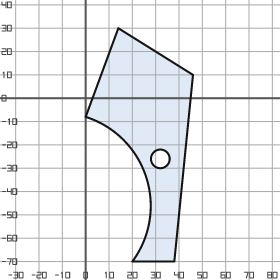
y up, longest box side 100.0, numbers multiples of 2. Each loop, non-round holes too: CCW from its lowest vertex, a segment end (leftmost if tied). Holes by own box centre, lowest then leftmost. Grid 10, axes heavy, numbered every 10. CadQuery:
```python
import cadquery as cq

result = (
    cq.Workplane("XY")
    .moveTo(20.0, -70.0)
    .lineTo(38.0, -70.0)
    .lineTo(46.0, 10.0)
    .lineTo(14.0, 30.0)
    .lineTo(0.0, -8.0)
    .threePointArc((26.0, -34.0), (20.0, -70.0))
    .close()
    .moveTo(32.0, -26.0)
    .circle(4.0)
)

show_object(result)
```